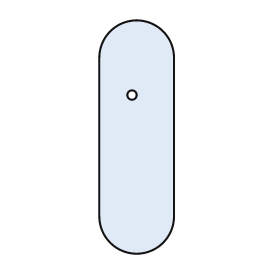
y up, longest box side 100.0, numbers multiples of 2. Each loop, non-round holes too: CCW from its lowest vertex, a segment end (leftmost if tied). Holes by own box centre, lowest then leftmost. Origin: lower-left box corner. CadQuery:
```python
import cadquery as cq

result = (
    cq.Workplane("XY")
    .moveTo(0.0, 16.0)
    .threePointArc((16.0, 0.0), (32.0, 16.0))
    .lineTo(32.0, 84.0)
    .threePointArc((16.0, 100.0), (0.0, 84.0))
    .close()
    .moveTo(14.0, 68.0)
    .circle(2.0)
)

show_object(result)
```